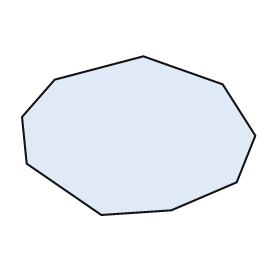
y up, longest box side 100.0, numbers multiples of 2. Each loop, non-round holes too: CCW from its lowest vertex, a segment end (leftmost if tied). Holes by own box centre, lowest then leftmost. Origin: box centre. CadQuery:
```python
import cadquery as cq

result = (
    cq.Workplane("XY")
    .moveTo(-16.0, -34.0)
    .lineTo(14.0, -32.0)
    .lineTo(42.0, -20.0)
    .lineTo(50.0, 0.0)
    .lineTo(36.0, 22.0)
    .lineTo(2.0, 34.0)
    .lineTo(-36.0, 24.0)
    .lineTo(-50.0, 8.0)
    .lineTo(-48.0, -12.0)
    .close()
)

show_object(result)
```